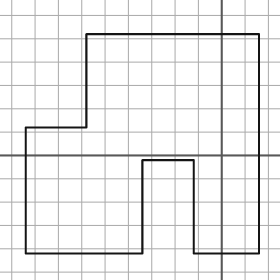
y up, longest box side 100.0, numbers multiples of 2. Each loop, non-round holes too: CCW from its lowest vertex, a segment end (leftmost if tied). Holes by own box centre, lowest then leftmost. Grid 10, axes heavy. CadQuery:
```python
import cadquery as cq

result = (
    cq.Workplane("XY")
    .moveTo(-84.0, -42.0)
    .lineTo(-34.0, -42.0)
    .lineTo(-34.0, -2.0)
    .lineTo(-12.0, -2.0)
    .lineTo(-12.0, -42.0)
    .lineTo(16.0, -42.0)
    .lineTo(16.0, 52.0)
    .lineTo(-58.0, 52.0)
    .lineTo(-58.0, 12.0)
    .lineTo(-84.0, 12.0)
    .close()
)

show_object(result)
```